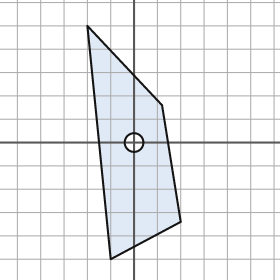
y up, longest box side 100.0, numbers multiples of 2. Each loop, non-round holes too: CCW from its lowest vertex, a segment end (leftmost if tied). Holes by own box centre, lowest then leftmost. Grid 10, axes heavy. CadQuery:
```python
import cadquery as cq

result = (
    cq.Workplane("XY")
    .moveTo(-10.0, -50.0)
    .lineTo(20.0, -34.0)
    .lineTo(12.0, 16.0)
    .lineTo(-20.0, 50.0)
    .close()
    .moveTo(0.0, 0.0)
    .circle(4.0)
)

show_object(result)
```